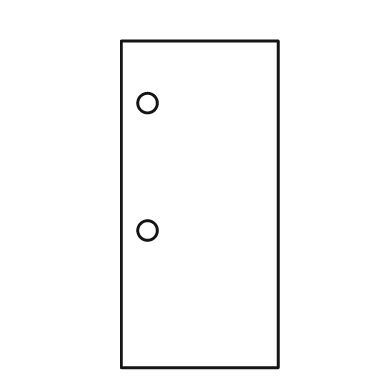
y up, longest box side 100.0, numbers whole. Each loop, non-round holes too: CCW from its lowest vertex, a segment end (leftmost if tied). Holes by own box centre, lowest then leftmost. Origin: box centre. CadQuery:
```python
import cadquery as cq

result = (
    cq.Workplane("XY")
    .moveTo(-24.0, -50.0)
    .lineTo(24.0, -50.0)
    .lineTo(24.0, 50.0)
    .lineTo(-24.0, 50.0)
    .close()
    .moveTo(-16.0, -8.0)
    .circle(3.0)
    .moveTo(-16.0, 31.0)
    .circle(3.0)
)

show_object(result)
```